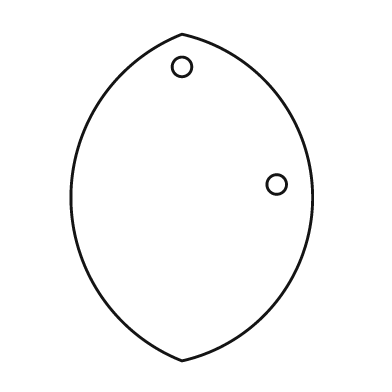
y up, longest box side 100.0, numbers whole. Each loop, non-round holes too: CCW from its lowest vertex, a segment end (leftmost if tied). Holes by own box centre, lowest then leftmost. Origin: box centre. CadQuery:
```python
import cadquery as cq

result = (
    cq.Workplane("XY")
    .moveTo(-3.0, -50.0)
    .threePointArc((37.0, 0.0), (-3.0, 50.0))
    .threePointArc((-37.0, 0.0), (-3.0, -50.0))
    .close()
    .moveTo(26.0, 4.0)
    .circle(3.0)
    .moveTo(-3.0, 40.0)
    .circle(3.0)
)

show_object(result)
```